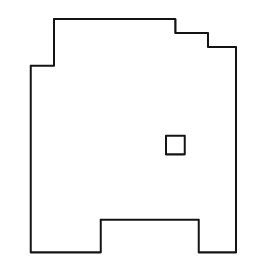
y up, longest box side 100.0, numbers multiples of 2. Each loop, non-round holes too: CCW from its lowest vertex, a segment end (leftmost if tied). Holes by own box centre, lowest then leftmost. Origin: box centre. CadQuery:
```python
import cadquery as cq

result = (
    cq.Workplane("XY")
    .moveTo(-44.0, -50.0)
    .lineTo(-14.0, -50.0)
    .lineTo(-14.0, -36.0)
    .lineTo(28.0, -36.0)
    .lineTo(28.0, -50.0)
    .lineTo(44.0, -50.0)
    .lineTo(44.0, 38.0)
    .lineTo(32.0, 38.0)
    .lineTo(32.0, 44.0)
    .lineTo(18.0, 44.0)
    .lineTo(18.0, 50.0)
    .lineTo(-34.0, 50.0)
    .lineTo(-34.0, 30.0)
    .lineTo(-44.0, 30.0)
    .close()
    .moveTo(14.0, -8.0)
    .lineTo(22.0, -8.0)
    .lineTo(22.0, 0.0)
    .lineTo(14.0, 0.0)
    .close()
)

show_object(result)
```